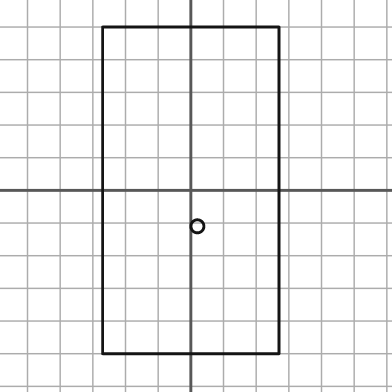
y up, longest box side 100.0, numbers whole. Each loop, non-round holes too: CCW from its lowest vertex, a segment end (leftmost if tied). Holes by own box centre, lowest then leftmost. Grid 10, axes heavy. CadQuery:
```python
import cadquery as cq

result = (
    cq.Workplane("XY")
    .moveTo(-27.0, -50.0)
    .lineTo(27.0, -50.0)
    .lineTo(27.0, 50.0)
    .lineTo(-27.0, 50.0)
    .close()
    .moveTo(2.0, -11.0)
    .circle(2.0)
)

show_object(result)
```